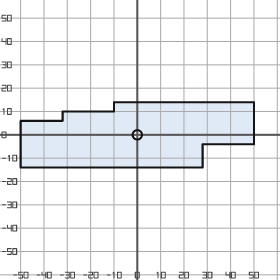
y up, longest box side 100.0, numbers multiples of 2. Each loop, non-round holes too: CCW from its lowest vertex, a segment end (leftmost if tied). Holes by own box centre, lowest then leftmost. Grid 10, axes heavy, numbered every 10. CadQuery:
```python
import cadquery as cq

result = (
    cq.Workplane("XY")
    .moveTo(-50.0, -14.0)
    .lineTo(28.0, -14.0)
    .lineTo(28.0, -4.0)
    .lineTo(50.0, -4.0)
    .lineTo(50.0, 14.0)
    .lineTo(-10.0, 14.0)
    .lineTo(-10.0, 10.0)
    .lineTo(-32.0, 10.0)
    .lineTo(-32.0, 6.0)
    .lineTo(-50.0, 6.0)
    .close()
    .moveTo(0.0, 0.0)
    .circle(2.0)
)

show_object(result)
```